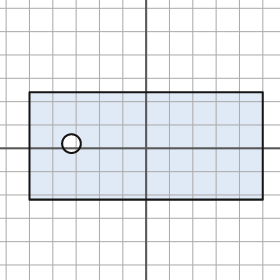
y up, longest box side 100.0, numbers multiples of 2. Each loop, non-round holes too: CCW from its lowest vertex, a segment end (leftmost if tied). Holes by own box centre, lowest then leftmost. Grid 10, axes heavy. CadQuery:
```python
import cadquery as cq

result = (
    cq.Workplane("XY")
    .moveTo(-50.0, -22.0)
    .lineTo(50.0, -22.0)
    .lineTo(50.0, 24.0)
    .lineTo(-50.0, 24.0)
    .close()
    .moveTo(-32.0, 2.0)
    .circle(4.0)
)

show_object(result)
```